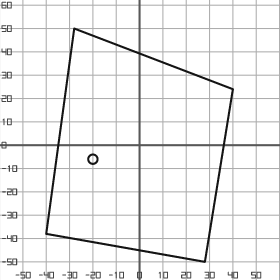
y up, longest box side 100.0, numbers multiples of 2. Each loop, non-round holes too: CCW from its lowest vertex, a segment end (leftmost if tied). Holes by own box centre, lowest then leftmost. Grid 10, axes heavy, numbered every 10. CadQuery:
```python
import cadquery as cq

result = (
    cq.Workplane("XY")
    .moveTo(28.0, -50.0)
    .lineTo(40.0, 24.0)
    .lineTo(-28.0, 50.0)
    .lineTo(-40.0, -38.0)
    .close()
    .moveTo(-20.0, -6.0)
    .circle(2.0)
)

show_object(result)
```